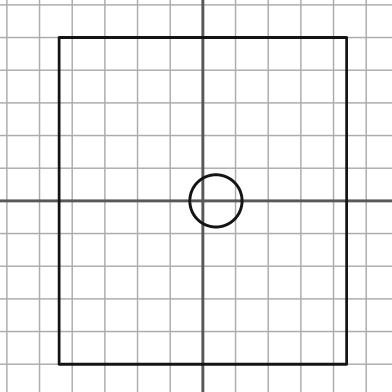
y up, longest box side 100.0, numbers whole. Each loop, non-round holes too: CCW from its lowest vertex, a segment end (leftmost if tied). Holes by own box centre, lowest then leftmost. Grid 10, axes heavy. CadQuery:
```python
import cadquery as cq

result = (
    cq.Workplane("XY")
    .moveTo(-44.0, -50.0)
    .lineTo(44.0, -50.0)
    .lineTo(44.0, 50.0)
    .lineTo(-44.0, 50.0)
    .close()
    .moveTo(4.0, 0.0)
    .circle(8.0)
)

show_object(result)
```